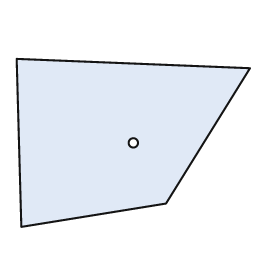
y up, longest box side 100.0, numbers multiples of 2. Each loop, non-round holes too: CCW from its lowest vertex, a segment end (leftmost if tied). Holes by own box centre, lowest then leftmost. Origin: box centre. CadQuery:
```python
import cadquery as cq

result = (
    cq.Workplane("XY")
    .moveTo(-48.0, -36.0)
    .lineTo(14.0, -26.0)
    .lineTo(50.0, 32.0)
    .lineTo(-50.0, 36.0)
    .close()
    .moveTo(0.0, 0.0)
    .circle(2.0)
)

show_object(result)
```